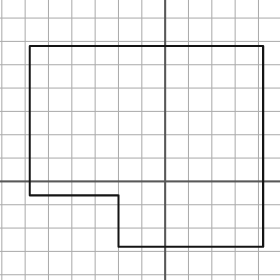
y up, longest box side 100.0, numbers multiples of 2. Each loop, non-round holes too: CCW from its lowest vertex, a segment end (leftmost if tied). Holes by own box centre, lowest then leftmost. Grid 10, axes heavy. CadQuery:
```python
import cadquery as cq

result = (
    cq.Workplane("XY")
    .moveTo(-20.0, -28.0)
    .lineTo(42.0, -28.0)
    .lineTo(42.0, 58.0)
    .lineTo(-58.0, 58.0)
    .lineTo(-58.0, -6.0)
    .lineTo(-20.0, -6.0)
    .close()
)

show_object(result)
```